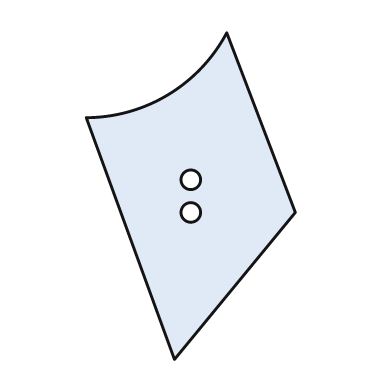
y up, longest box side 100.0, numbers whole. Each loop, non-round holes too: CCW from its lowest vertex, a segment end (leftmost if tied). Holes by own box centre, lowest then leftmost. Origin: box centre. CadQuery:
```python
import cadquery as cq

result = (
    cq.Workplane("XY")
    .moveTo(-5.0, -50.0)
    .lineTo(32.0, -5.0)
    .lineTo(11.0, 50.0)
    .threePointArc((-7.0, 31.0), (-32.0, 24.0))
    .close()
    .moveTo(0.0, -5.0)
    .circle(3.0)
    .moveTo(0.0, 5.0)
    .circle(3.0)
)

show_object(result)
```